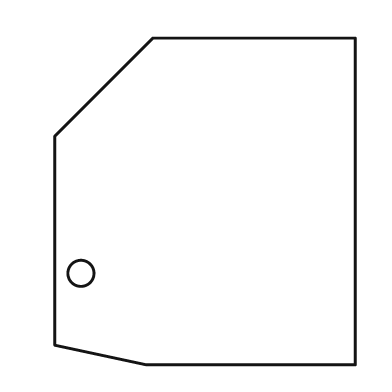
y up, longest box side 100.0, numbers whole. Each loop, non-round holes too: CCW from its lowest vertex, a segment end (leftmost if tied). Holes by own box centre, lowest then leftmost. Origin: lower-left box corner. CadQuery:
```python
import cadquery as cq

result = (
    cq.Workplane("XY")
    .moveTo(28.0, 0.0)
    .lineTo(92.0, 0.0)
    .lineTo(92.0, 100.0)
    .lineTo(30.0, 100.0)
    .lineTo(0.0, 70.0)
    .lineTo(0.0, 6.0)
    .close()
    .moveTo(8.0, 28.0)
    .circle(4.0)
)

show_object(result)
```